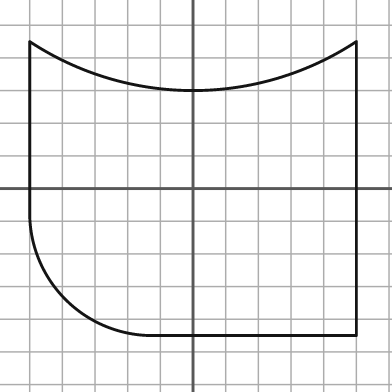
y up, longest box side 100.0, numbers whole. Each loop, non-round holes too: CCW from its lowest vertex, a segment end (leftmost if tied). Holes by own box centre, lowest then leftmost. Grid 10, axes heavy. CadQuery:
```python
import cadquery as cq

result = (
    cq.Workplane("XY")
    .moveTo(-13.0, -45.0)
    .lineTo(50.0, -45.0)
    .lineTo(50.0, 45.0)
    .threePointArc((0.0, 30.0), (-50.0, 45.0))
    .lineTo(-50.0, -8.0)
    .threePointArc((-39.0, -34.0), (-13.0, -45.0))
    .close()
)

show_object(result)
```